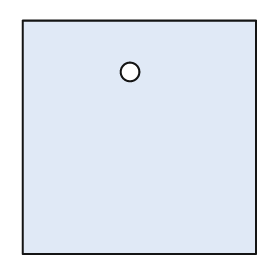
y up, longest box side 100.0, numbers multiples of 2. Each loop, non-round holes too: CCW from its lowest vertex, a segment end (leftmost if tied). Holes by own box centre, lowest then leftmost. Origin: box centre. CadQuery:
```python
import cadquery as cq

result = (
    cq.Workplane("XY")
    .moveTo(-50.0, -50.0)
    .lineTo(50.0, -50.0)
    .lineTo(50.0, 50.0)
    .lineTo(-50.0, 50.0)
    .close()
    .moveTo(-4.0, 28.0)
    .circle(4.0)
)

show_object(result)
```